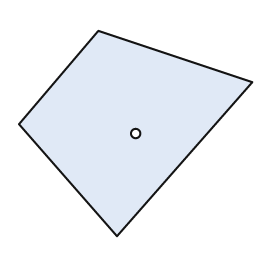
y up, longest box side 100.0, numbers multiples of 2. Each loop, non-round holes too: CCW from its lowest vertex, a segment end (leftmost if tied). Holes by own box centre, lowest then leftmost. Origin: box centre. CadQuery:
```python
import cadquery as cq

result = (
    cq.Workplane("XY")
    .moveTo(-8.0, -44.0)
    .lineTo(50.0, 22.0)
    .lineTo(-16.0, 44.0)
    .lineTo(-50.0, 4.0)
    .close()
    .moveTo(0.0, 0.0)
    .circle(2.0)
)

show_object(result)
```